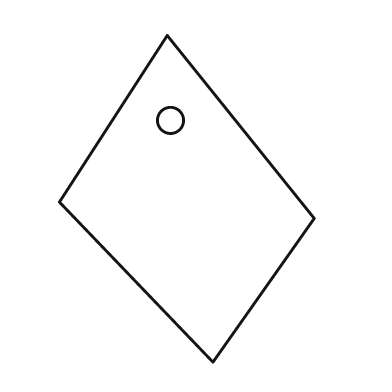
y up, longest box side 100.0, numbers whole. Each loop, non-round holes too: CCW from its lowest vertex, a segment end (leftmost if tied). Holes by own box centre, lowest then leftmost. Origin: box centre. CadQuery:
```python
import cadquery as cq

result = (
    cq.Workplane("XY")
    .moveTo(8.0, -50.0)
    .lineTo(39.0, -6.0)
    .lineTo(-6.0, 50.0)
    .lineTo(-39.0, -1.0)
    .close()
    .moveTo(-5.0, 24.0)
    .circle(4.0)
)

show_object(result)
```